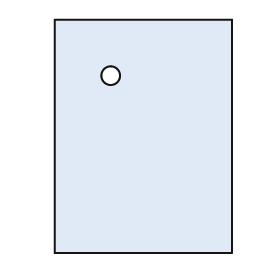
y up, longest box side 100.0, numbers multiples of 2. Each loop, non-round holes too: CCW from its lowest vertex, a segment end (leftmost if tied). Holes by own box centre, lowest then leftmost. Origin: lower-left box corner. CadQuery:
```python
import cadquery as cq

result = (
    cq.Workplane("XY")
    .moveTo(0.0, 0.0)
    .lineTo(76.0, 0.0)
    .lineTo(76.0, 100.0)
    .lineTo(0.0, 100.0)
    .close()
    .moveTo(24.0, 76.0)
    .circle(4.0)
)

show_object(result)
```